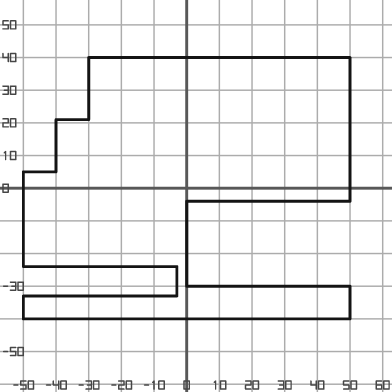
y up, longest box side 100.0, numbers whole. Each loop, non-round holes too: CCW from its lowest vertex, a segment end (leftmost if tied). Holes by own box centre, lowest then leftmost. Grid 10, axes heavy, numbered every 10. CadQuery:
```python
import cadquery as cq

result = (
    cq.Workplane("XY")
    .moveTo(-50.0, -40.0)
    .lineTo(50.0, -40.0)
    .lineTo(50.0, -30.0)
    .lineTo(0.0, -30.0)
    .lineTo(0.0, -4.0)
    .lineTo(50.0, -4.0)
    .lineTo(50.0, 40.0)
    .lineTo(-30.0, 40.0)
    .lineTo(-30.0, 21.0)
    .lineTo(-40.0, 21.0)
    .lineTo(-40.0, 5.0)
    .lineTo(-50.0, 5.0)
    .lineTo(-50.0, -24.0)
    .lineTo(-3.0, -24.0)
    .lineTo(-3.0, -33.0)
    .lineTo(-50.0, -33.0)
    .close()
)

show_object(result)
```